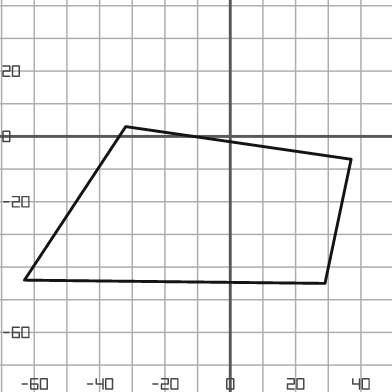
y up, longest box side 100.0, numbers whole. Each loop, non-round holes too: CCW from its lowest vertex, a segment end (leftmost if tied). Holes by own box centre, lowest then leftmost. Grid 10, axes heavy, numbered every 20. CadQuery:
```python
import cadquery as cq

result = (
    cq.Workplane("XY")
    .moveTo(29.0, -45.0)
    .lineTo(37.0, -7.0)
    .lineTo(-32.0, 3.0)
    .lineTo(-63.0, -44.0)
    .close()
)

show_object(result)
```